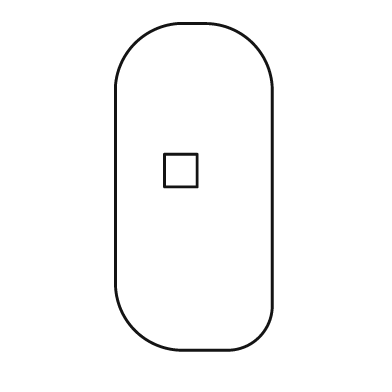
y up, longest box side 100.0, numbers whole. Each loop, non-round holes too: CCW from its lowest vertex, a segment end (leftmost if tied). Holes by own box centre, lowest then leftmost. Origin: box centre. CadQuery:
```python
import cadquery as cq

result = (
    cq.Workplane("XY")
    .moveTo(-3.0, -50.0)
    .lineTo(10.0, -50.0)
    .threePointArc((20.0, -46.0), (24.0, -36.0))
    .lineTo(24.0, 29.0)
    .threePointArc((18.0, 44.0), (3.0, 50.0))
    .lineTo(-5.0, 50.0)
    .threePointArc((-18.0, 44.0), (-24.0, 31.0))
    .lineTo(-24.0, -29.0)
    .threePointArc((-18.0, -44.0), (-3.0, -50.0))
    .close()
    .moveTo(-9.0, 0.0)
    .lineTo(1.0, 0.0)
    .lineTo(1.0, 10.0)
    .lineTo(-9.0, 10.0)
    .close()
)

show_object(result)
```